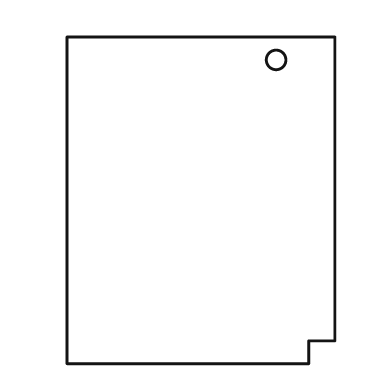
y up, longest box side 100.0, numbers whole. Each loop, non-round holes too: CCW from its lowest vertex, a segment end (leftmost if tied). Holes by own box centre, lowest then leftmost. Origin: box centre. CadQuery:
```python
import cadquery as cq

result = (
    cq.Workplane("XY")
    .moveTo(-41.0, -50.0)
    .lineTo(33.0, -50.0)
    .lineTo(33.0, -43.0)
    .lineTo(41.0, -43.0)
    .lineTo(41.0, 50.0)
    .lineTo(-41.0, 50.0)
    .close()
    .moveTo(23.0, 43.0)
    .circle(3.0)
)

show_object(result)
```